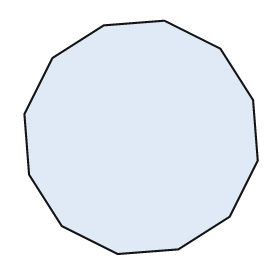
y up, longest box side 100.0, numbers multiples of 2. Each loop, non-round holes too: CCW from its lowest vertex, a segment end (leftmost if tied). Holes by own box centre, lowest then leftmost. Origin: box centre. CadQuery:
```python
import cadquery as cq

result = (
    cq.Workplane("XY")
    .moveTo(-10.0, -50.0)
    .lineTo(16.0, -48.0)
    .lineTo(38.0, -34.0)
    .lineTo(50.0, -10.0)
    .lineTo(48.0, 16.0)
    .lineTo(34.0, 38.0)
    .lineTo(10.0, 50.0)
    .lineTo(-16.0, 48.0)
    .lineTo(-38.0, 34.0)
    .lineTo(-50.0, 10.0)
    .lineTo(-48.0, -16.0)
    .lineTo(-34.0, -38.0)
    .close()
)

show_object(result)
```